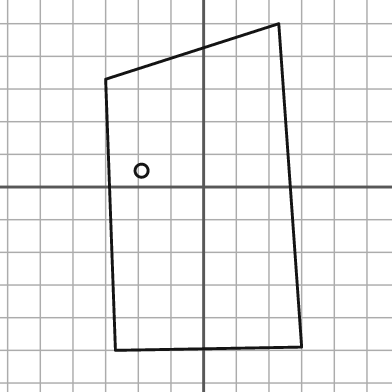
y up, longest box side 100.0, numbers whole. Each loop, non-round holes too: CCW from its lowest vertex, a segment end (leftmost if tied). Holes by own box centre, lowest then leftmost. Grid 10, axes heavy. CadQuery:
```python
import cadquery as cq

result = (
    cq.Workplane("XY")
    .moveTo(-27.0, -50.0)
    .lineTo(30.0, -49.0)
    .lineTo(23.0, 50.0)
    .lineTo(-30.0, 33.0)
    .close()
    .moveTo(-19.0, 5.0)
    .circle(2.0)
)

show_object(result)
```